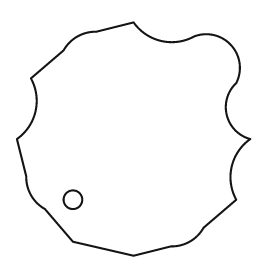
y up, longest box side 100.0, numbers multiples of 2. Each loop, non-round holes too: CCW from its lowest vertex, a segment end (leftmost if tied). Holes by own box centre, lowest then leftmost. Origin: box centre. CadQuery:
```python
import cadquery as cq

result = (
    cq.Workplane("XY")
    .moveTo(0.0, -50.0)
    .lineTo(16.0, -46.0)
    .threePointArc((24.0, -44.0), (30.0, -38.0))
    .lineTo(44.0, -26.0)
    .threePointArc((42.0, -12.0), (50.0, 0.0))
    .threePointArc((40.0, 10.0), (44.0, 24.0))
    .threePointArc((42.0, 40.0), (26.0, 44.0))
    .threePointArc((12.0, 42.0), (0.0, 50.0))
    .lineTo(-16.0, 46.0)
    .threePointArc((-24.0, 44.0), (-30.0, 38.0))
    .lineTo(-44.0, 26.0)
    .threePointArc((-42.0, 12.0), (-50.0, 0.0))
    .lineTo(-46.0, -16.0)
    .threePointArc((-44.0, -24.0), (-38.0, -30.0))
    .lineTo(-26.0, -44.0)
    .close()
    .moveTo(-26.0, -26.0)
    .circle(4.0)
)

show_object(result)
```